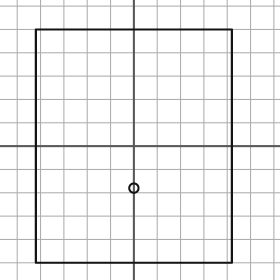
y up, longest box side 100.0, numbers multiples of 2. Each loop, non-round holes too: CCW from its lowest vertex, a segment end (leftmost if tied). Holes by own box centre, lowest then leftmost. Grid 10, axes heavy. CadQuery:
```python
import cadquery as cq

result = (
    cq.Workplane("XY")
    .moveTo(-42.0, -50.0)
    .lineTo(42.0, -50.0)
    .lineTo(42.0, 50.0)
    .lineTo(-42.0, 50.0)
    .close()
    .moveTo(0.0, -18.0)
    .circle(2.0)
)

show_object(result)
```